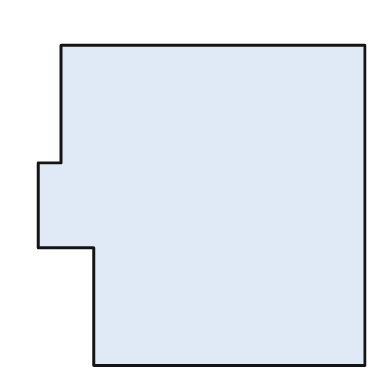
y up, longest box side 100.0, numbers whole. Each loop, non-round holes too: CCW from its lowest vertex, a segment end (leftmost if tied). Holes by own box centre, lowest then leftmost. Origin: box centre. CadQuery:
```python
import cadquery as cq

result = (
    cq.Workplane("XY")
    .moveTo(-33.0, -49.0)
    .lineTo(50.0, -49.0)
    .lineTo(50.0, 49.0)
    .lineTo(-43.0, 49.0)
    .lineTo(-43.0, 13.0)
    .lineTo(-50.0, 13.0)
    .lineTo(-50.0, -13.0)
    .lineTo(-33.0, -13.0)
    .close()
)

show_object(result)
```